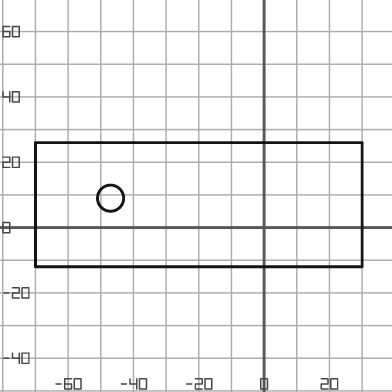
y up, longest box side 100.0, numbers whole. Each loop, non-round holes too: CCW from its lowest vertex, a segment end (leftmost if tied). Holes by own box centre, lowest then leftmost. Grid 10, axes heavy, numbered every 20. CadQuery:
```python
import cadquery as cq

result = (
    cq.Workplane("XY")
    .moveTo(-70.0, -12.0)
    .lineTo(30.0, -12.0)
    .lineTo(30.0, 26.0)
    .lineTo(-70.0, 26.0)
    .close()
    .moveTo(-47.0, 9.0)
    .circle(4.0)
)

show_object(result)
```